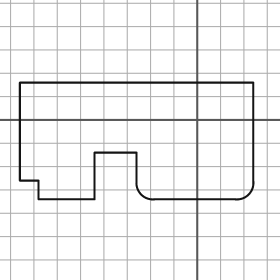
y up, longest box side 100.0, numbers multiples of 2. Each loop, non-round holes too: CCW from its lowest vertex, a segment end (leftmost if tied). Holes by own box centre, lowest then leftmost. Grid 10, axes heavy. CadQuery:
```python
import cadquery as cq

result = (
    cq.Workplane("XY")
    .moveTo(-68.0, -34.0)
    .lineTo(-44.0, -34.0)
    .lineTo(-44.0, -14.0)
    .lineTo(-26.0, -14.0)
    .lineTo(-26.0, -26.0)
    .threePointArc((-24.0, -32.0), (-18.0, -34.0))
    .lineTo(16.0, -34.0)
    .threePointArc((22.0, -32.0), (24.0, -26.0))
    .lineTo(24.0, 16.0)
    .lineTo(-76.0, 16.0)
    .lineTo(-76.0, -26.0)
    .lineTo(-68.0, -26.0)
    .close()
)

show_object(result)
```